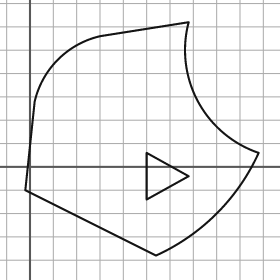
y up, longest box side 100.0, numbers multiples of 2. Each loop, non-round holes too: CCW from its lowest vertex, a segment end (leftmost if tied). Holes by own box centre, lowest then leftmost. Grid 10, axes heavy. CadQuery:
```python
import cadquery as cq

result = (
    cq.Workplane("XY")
    .moveTo(54.0, -38.0)
    .threePointArc((80.0, -20.0), (98.0, 6.0))
    .threePointArc((72.0, 28.0), (68.0, 62.0))
    .lineTo(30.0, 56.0)
    .threePointArc((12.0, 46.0), (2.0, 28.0))
    .lineTo(-2.0, -10.0)
    .close()
    .moveTo(50.0, -14.0)
    .lineTo(68.0, -4.0)
    .lineTo(50.0, 6.0)
    .close()
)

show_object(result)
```